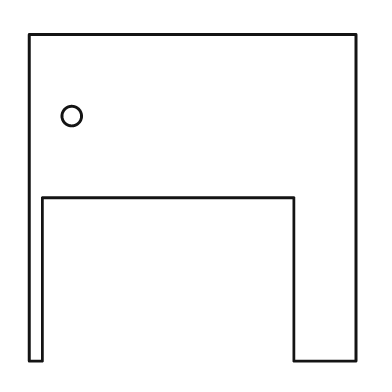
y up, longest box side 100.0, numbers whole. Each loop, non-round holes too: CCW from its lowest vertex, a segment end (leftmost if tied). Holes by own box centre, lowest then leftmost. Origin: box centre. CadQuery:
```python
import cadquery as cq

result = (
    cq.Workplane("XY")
    .moveTo(-50.0, -50.0)
    .lineTo(-46.0, -50.0)
    .lineTo(-46.0, 0.0)
    .lineTo(31.0, 0.0)
    .lineTo(31.0, -50.0)
    .lineTo(50.0, -50.0)
    .lineTo(50.0, 50.0)
    .lineTo(-50.0, 50.0)
    .close()
    .moveTo(-37.0, 25.0)
    .circle(3.0)
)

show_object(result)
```